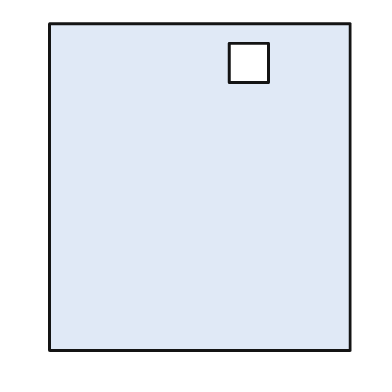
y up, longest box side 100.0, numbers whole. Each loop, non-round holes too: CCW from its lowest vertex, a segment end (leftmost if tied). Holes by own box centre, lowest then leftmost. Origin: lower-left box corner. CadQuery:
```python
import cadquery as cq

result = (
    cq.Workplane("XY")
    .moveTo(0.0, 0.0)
    .lineTo(92.0, 0.0)
    .lineTo(92.0, 100.0)
    .lineTo(0.0, 100.0)
    .close()
    .moveTo(55.0, 82.0)
    .lineTo(67.0, 82.0)
    .lineTo(67.0, 94.0)
    .lineTo(55.0, 94.0)
    .close()
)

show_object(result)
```